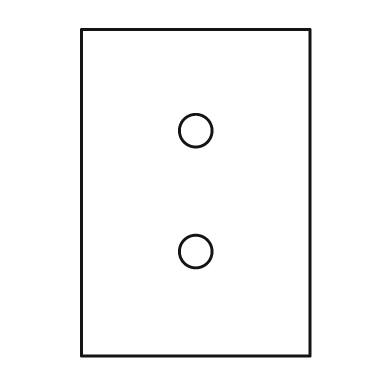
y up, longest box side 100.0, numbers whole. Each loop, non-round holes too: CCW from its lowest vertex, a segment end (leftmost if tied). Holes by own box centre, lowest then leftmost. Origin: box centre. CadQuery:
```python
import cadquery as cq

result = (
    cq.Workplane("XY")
    .moveTo(-35.0, -50.0)
    .lineTo(35.0, -50.0)
    .lineTo(35.0, 50.0)
    .lineTo(-35.0, 50.0)
    .close()
    .moveTo(0.0, -18.0)
    .circle(5.0)
    .moveTo(0.0, 19.0)
    .circle(5.0)
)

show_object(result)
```